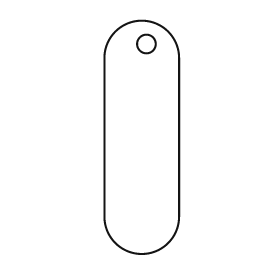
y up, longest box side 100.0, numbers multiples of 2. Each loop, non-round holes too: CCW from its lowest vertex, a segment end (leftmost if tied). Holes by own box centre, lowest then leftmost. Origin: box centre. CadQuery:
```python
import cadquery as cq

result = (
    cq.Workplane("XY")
    .moveTo(-16.0, -34.0)
    .threePointArc((0.0, -50.0), (16.0, -34.0))
    .lineTo(16.0, 34.0)
    .threePointArc((0.0, 50.0), (-16.0, 34.0))
    .close()
    .moveTo(2.0, 40.0)
    .circle(4.0)
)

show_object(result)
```